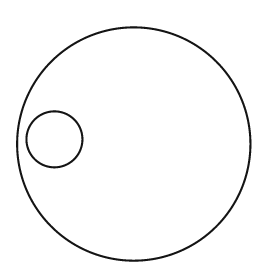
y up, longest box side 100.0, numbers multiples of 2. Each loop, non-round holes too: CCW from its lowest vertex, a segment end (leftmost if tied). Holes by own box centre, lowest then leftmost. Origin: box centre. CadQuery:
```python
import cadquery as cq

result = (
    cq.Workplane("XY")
    .moveTo(0.0, 0.0)
    .circle(50.0)
    .moveTo(-34.0, 2.0)
    .circle(12.0)
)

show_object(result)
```